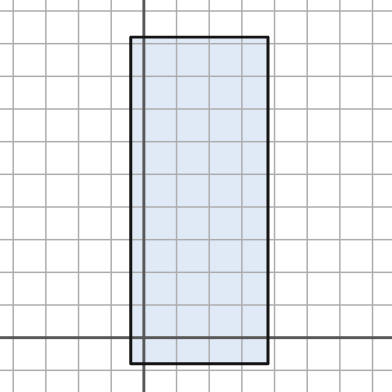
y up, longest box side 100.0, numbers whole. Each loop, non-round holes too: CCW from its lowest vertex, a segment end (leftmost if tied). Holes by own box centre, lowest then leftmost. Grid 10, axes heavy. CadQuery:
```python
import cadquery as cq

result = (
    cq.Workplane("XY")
    .moveTo(-4.0, -8.0)
    .lineTo(38.0, -8.0)
    .lineTo(38.0, 92.0)
    .lineTo(-4.0, 92.0)
    .close()
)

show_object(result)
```